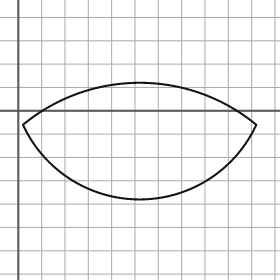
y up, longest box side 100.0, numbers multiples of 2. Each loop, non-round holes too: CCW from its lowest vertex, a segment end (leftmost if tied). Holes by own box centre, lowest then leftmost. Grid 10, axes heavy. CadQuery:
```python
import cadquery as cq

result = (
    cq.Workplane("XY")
    .moveTo(2.0, -6.0)
    .threePointArc((52.0, -38.0), (102.0, -6.0))
    .threePointArc((52.0, 12.0), (2.0, -6.0))
    .close()
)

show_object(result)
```